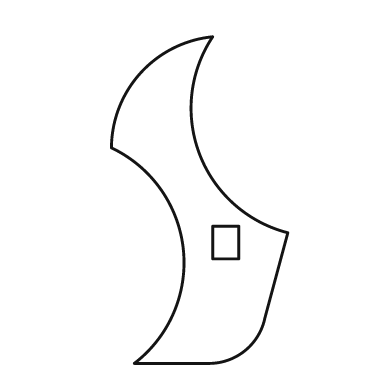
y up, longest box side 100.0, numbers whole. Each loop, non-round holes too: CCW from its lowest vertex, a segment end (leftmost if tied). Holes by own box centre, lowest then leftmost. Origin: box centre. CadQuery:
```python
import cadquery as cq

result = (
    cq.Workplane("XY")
    .moveTo(-20.0, -50.0)
    .lineTo(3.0, -50.0)
    .threePointArc((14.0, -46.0), (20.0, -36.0))
    .lineTo(27.0, -10.0)
    .threePointArc((0.0, 14.0), (4.0, 50.0))
    .threePointArc((-18.0, 39.0), (-27.0, 16.0))
    .threePointArc((-5.0, -15.0), (-20.0, -50.0))
    .close()
    .moveTo(4.0, -18.0)
    .lineTo(12.0, -18.0)
    .lineTo(12.0, -8.0)
    .lineTo(4.0, -8.0)
    .close()
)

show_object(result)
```